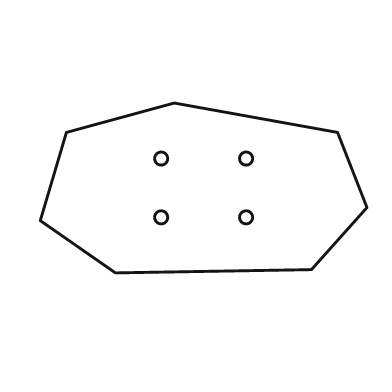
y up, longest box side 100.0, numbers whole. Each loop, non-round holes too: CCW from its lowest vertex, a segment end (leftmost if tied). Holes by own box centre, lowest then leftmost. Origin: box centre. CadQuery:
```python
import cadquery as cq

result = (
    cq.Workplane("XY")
    .moveTo(-27.0, -26.0)
    .lineTo(33.0, -25.0)
    .lineTo(50.0, -6.0)
    .lineTo(41.0, 17.0)
    .lineTo(-9.0, 26.0)
    .lineTo(-42.0, 17.0)
    .lineTo(-50.0, -10.0)
    .close()
    .moveTo(-13.0, -9.0)
    .circle(2.0)
    .moveTo(13.0, -9.0)
    .circle(2.0)
    .moveTo(-13.0, 9.0)
    .circle(2.0)
    .moveTo(13.0, 9.0)
    .circle(2.0)
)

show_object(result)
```